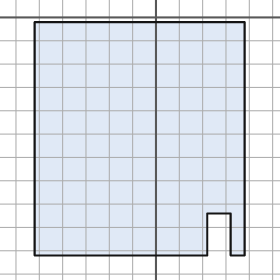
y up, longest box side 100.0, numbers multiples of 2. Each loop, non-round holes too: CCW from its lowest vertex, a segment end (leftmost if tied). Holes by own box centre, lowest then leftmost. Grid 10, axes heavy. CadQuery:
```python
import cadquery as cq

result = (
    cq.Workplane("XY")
    .moveTo(-52.0, -102.0)
    .lineTo(22.0, -102.0)
    .lineTo(22.0, -84.0)
    .lineTo(32.0, -84.0)
    .lineTo(32.0, -102.0)
    .lineTo(38.0, -102.0)
    .lineTo(38.0, -2.0)
    .lineTo(-52.0, -2.0)
    .close()
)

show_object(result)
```